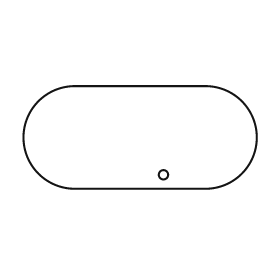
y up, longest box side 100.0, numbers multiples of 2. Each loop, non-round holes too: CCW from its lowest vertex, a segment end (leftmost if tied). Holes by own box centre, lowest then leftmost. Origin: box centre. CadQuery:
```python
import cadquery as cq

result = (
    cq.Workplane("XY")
    .moveTo(-28.0, -22.0)
    .lineTo(28.0, -22.0)
    .threePointArc((50.0, 0.0), (28.0, 22.0))
    .lineTo(-28.0, 22.0)
    .threePointArc((-50.0, 0.0), (-28.0, -22.0))
    .close()
    .moveTo(10.0, -16.0)
    .circle(2.0)
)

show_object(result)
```